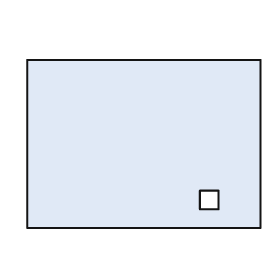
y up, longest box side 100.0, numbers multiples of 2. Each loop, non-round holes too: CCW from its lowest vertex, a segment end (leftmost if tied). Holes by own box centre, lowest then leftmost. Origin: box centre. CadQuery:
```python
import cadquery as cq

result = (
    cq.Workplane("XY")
    .moveTo(-50.0, -36.0)
    .lineTo(50.0, -36.0)
    .lineTo(50.0, 36.0)
    .lineTo(-50.0, 36.0)
    .close()
    .moveTo(24.0, -28.0)
    .lineTo(32.0, -28.0)
    .lineTo(32.0, -20.0)
    .lineTo(24.0, -20.0)
    .close()
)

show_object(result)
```